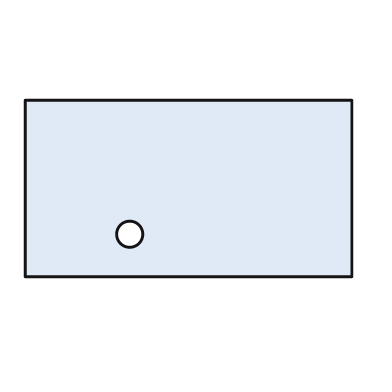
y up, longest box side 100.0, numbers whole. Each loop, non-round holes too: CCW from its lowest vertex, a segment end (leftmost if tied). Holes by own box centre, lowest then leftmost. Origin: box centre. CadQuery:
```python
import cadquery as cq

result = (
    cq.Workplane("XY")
    .moveTo(-50.0, -27.0)
    .lineTo(50.0, -27.0)
    .lineTo(50.0, 27.0)
    .lineTo(-50.0, 27.0)
    .close()
    .moveTo(-18.0, -14.0)
    .circle(4.0)
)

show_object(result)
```